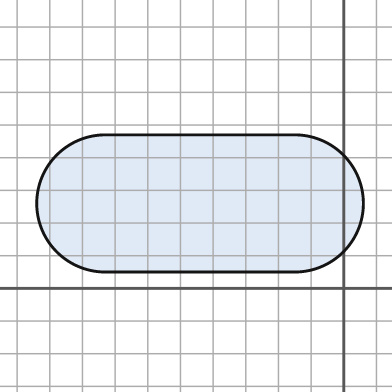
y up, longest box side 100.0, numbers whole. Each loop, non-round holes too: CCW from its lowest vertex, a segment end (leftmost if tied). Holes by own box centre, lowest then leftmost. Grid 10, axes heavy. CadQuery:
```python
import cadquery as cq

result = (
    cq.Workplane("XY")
    .moveTo(-73.0, 5.0)
    .lineTo(-15.0, 5.0)
    .threePointArc((6.0, 26.0), (-15.0, 47.0))
    .lineTo(-73.0, 47.0)
    .threePointArc((-94.0, 26.0), (-73.0, 5.0))
    .close()
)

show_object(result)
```